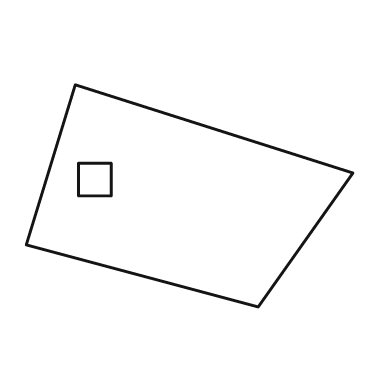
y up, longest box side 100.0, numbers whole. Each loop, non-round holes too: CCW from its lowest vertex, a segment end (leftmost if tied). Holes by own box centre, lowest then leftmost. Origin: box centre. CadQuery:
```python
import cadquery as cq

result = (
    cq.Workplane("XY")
    .moveTo(21.0, -34.0)
    .lineTo(50.0, 7.0)
    .lineTo(-35.0, 34.0)
    .lineTo(-50.0, -15.0)
    .close()
    .moveTo(-34.0, 0.0)
    .lineTo(-24.0, 0.0)
    .lineTo(-24.0, 10.0)
    .lineTo(-34.0, 10.0)
    .close()
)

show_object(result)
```